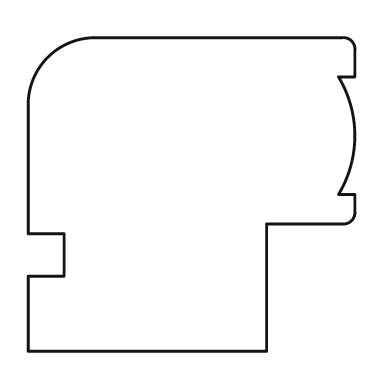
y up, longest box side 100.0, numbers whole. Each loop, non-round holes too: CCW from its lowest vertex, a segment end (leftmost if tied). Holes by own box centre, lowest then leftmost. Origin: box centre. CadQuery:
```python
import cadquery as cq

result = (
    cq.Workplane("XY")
    .moveTo(-50.0, -48.0)
    .lineTo(23.0, -48.0)
    .lineTo(23.0, -9.0)
    .lineTo(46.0, -9.0)
    .threePointArc((49.0, -8.0), (50.0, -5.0))
    .lineTo(50.0, 0.0)
    .lineTo(45.0, 0.0)
    .threePointArc((50.0, 18.0), (45.0, 36.0))
    .lineTo(50.0, 36.0)
    .lineTo(50.0, 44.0)
    .threePointArc((49.0, 47.0), (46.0, 48.0))
    .lineTo(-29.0, 48.0)
    .threePointArc((-44.0, 42.0), (-50.0, 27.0))
    .lineTo(-50.0, -12.0)
    .lineTo(-39.0, -12.0)
    .lineTo(-39.0, -25.0)
    .lineTo(-50.0, -25.0)
    .close()
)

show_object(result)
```